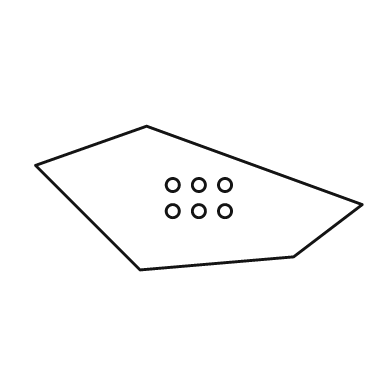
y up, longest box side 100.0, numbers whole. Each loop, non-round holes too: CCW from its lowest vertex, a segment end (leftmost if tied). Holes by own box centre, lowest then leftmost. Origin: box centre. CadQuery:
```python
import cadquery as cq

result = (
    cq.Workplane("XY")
    .moveTo(-18.0, -22.0)
    .lineTo(29.0, -18.0)
    .lineTo(50.0, -2.0)
    .lineTo(-16.0, 22.0)
    .lineTo(-50.0, 10.0)
    .close()
    .moveTo(-8.0, -4.0)
    .circle(2.0)
    .moveTo(0.0, -4.0)
    .circle(2.0)
    .moveTo(8.0, -4.0)
    .circle(2.0)
    .moveTo(-8.0, 4.0)
    .circle(2.0)
    .moveTo(0.0, 4.0)
    .circle(2.0)
    .moveTo(8.0, 4.0)
    .circle(2.0)
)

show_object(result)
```